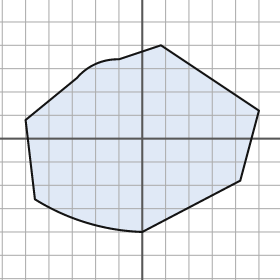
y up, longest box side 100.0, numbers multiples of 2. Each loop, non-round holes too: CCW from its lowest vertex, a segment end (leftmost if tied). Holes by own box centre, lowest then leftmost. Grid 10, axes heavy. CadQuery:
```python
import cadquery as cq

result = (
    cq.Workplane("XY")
    .moveTo(0.0, -40.0)
    .lineTo(42.0, -18.0)
    .lineTo(50.0, 12.0)
    .lineTo(8.0, 40.0)
    .lineTo(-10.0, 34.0)
    .threePointArc((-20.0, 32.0), (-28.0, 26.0))
    .lineTo(-50.0, 8.0)
    .lineTo(-46.0, -26.0)
    .threePointArc((-24.0, -36.0), (0.0, -40.0))
    .close()
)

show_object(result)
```